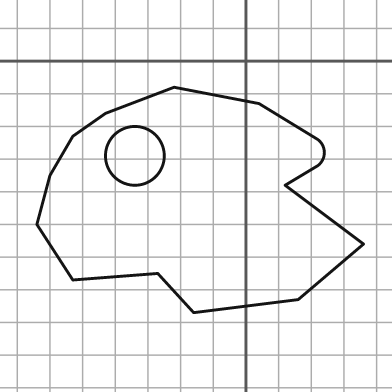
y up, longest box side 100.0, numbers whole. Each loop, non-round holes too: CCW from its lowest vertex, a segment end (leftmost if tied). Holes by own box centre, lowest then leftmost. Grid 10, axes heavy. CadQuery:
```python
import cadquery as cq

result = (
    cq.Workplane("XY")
    .moveTo(-16.0, -77.0)
    .lineTo(16.0, -73.0)
    .lineTo(36.0, -56.0)
    .lineTo(12.0, -38.0)
    .lineTo(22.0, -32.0)
    .threePointArc((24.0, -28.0), (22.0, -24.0))
    .lineTo(4.0, -13.0)
    .lineTo(-22.0, -8.0)
    .lineTo(-43.0, -16.0)
    .lineTo(-53.0, -23.0)
    .lineTo(-60.0, -35.0)
    .lineTo(-64.0, -50.0)
    .lineTo(-53.0, -67.0)
    .lineTo(-27.0, -65.0)
    .close()
    .moveTo(-34.0, -29.0)
    .circle(9.0)
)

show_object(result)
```